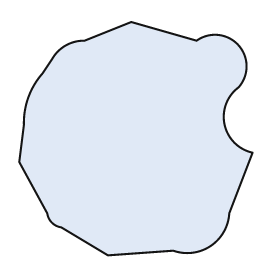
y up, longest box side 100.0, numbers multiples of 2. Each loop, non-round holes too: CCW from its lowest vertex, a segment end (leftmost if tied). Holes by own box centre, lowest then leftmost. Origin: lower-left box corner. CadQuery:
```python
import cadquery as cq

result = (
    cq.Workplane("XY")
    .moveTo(38.0, 0.0)
    .lineTo(66.0, 2.0)
    .threePointArc((82.0, 4.0), (90.0, 18.0))
    .lineTo(100.0, 44.0)
    .threePointArc((88.0, 56.0), (94.0, 72.0))
    .threePointArc((94.0, 90.0), (76.0, 92.0))
    .lineTo(48.0, 100.0)
    .lineTo(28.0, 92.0)
    .threePointArc((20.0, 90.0), (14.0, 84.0))
    .lineTo(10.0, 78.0)
    .threePointArc((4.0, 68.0), (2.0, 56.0))
    .lineTo(0.0, 40.0)
    .lineTo(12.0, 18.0)
    .threePointArc((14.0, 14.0), (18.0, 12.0))
    .close()
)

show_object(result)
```